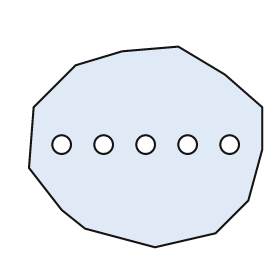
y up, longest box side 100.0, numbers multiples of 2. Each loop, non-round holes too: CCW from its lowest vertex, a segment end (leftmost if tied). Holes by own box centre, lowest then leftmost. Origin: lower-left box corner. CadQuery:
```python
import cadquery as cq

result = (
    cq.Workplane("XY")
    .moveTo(54.0, 0.0)
    .lineTo(80.0, 6.0)
    .lineTo(94.0, 20.0)
    .lineTo(100.0, 42.0)
    .lineTo(100.0, 60.0)
    .lineTo(84.0, 74.0)
    .lineTo(64.0, 86.0)
    .lineTo(40.0, 84.0)
    .lineTo(20.0, 78.0)
    .lineTo(2.0, 60.0)
    .lineTo(0.0, 34.0)
    .lineTo(14.0, 16.0)
    .lineTo(24.0, 8.0)
    .close()
    .moveTo(14.0, 44.0)
    .circle(4.0)
    .moveTo(32.0, 44.0)
    .circle(4.0)
    .moveTo(50.0, 44.0)
    .circle(4.0)
    .moveTo(68.0, 44.0)
    .circle(4.0)
    .moveTo(86.0, 44.0)
    .circle(4.0)
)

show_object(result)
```